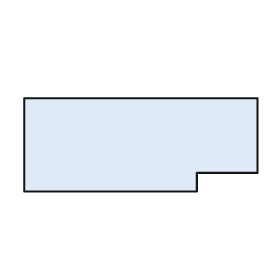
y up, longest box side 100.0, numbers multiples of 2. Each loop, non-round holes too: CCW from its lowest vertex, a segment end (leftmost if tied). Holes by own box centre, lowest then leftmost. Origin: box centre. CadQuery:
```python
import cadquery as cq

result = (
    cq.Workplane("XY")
    .moveTo(-50.0, -20.0)
    .lineTo(24.0, -20.0)
    .lineTo(24.0, -12.0)
    .lineTo(50.0, -12.0)
    .lineTo(50.0, 20.0)
    .lineTo(-50.0, 20.0)
    .close()
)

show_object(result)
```